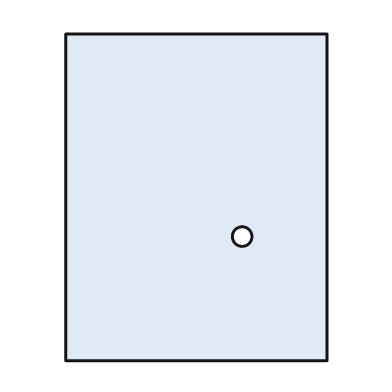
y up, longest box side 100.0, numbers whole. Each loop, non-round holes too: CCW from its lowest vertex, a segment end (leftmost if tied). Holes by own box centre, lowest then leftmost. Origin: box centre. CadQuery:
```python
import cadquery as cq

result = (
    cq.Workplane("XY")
    .moveTo(-40.0, -50.0)
    .lineTo(40.0, -50.0)
    .lineTo(40.0, 50.0)
    .lineTo(-40.0, 50.0)
    .close()
    .moveTo(14.0, -12.0)
    .circle(3.0)
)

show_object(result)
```